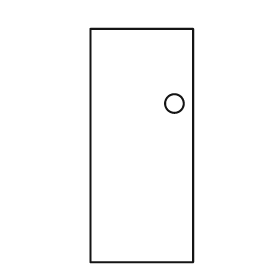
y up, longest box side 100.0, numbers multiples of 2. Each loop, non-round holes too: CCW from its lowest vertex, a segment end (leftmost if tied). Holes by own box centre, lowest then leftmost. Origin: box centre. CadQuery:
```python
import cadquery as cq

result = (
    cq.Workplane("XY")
    .moveTo(-22.0, -50.0)
    .lineTo(22.0, -50.0)
    .lineTo(22.0, 50.0)
    .lineTo(-22.0, 50.0)
    .close()
    .moveTo(14.0, 18.0)
    .circle(4.0)
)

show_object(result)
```